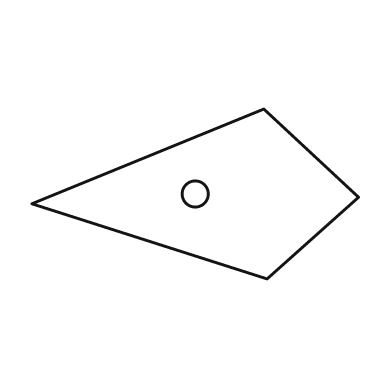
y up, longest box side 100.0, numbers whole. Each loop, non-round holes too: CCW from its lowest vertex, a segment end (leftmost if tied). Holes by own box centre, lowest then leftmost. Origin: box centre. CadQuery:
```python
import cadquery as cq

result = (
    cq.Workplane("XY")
    .moveTo(22.0, -26.0)
    .lineTo(50.0, -1.0)
    .lineTo(21.0, 26.0)
    .lineTo(-50.0, -3.0)
    .close()
    .moveTo(0.0, 0.0)
    .circle(4.0)
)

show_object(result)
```